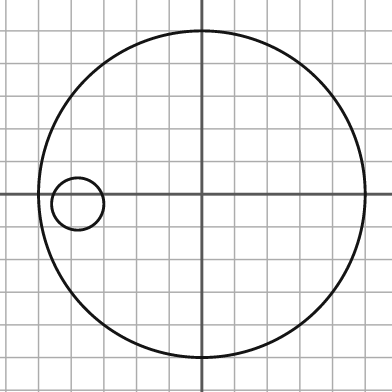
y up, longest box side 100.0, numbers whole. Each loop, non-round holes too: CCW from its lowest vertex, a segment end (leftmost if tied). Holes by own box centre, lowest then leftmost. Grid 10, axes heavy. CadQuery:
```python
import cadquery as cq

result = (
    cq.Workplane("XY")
    .moveTo(0.0, 0.0)
    .circle(50.0)
    .moveTo(-38.0, -3.0)
    .circle(8.0)
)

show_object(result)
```